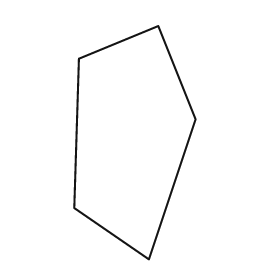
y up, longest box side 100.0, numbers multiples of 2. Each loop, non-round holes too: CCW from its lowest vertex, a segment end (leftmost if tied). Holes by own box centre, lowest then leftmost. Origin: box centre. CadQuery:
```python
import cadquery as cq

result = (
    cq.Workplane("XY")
    .moveTo(6.0, -50.0)
    .lineTo(26.0, 10.0)
    .lineTo(10.0, 50.0)
    .lineTo(-24.0, 36.0)
    .lineTo(-26.0, -28.0)
    .close()
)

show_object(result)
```